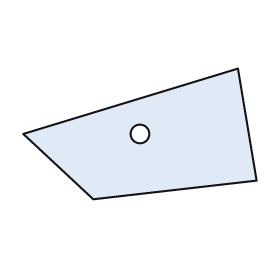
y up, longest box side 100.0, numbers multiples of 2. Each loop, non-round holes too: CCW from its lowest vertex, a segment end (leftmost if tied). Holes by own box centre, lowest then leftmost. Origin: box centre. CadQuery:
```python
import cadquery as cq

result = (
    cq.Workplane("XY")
    .moveTo(-20.0, -28.0)
    .lineTo(50.0, -20.0)
    .lineTo(42.0, 28.0)
    .lineTo(-50.0, 0.0)
    .close()
    .moveTo(0.0, 0.0)
    .circle(4.0)
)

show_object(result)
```